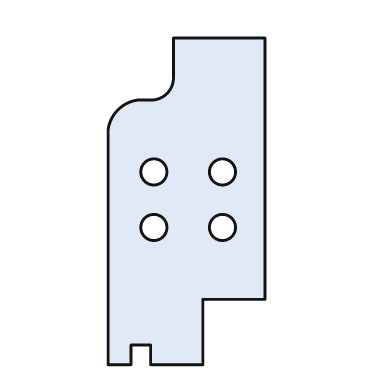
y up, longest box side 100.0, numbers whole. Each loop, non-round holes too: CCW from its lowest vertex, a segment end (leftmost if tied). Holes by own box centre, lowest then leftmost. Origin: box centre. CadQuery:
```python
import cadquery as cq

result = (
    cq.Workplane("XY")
    .moveTo(-24.0, -50.0)
    .lineTo(-17.0, -50.0)
    .lineTo(-17.0, -44.0)
    .lineTo(-11.0, -44.0)
    .lineTo(-11.0, -50.0)
    .lineTo(5.0, -50.0)
    .lineTo(5.0, -30.0)
    .lineTo(24.0, -30.0)
    .lineTo(24.0, 50.0)
    .lineTo(-4.0, 50.0)
    .lineTo(-4.0, 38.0)
    .threePointArc((-6.0, 33.0), (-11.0, 31.0))
    .lineTo(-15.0, 31.0)
    .threePointArc((-21.0, 28.0), (-24.0, 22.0))
    .close()
    .moveTo(-10.0, -8.0)
    .circle(4.0)
    .moveTo(11.0, -8.0)
    .circle(4.0)
    .moveTo(-10.0, 9.0)
    .circle(4.0)
    .moveTo(11.0, 9.0)
    .circle(4.0)
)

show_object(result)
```